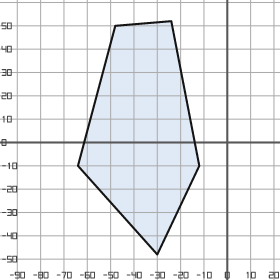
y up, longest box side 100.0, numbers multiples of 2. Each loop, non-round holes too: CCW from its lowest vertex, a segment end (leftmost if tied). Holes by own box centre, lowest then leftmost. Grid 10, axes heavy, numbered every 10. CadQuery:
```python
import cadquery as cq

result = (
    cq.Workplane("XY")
    .moveTo(-30.0, -48.0)
    .lineTo(-12.0, -10.0)
    .lineTo(-24.0, 52.0)
    .lineTo(-48.0, 50.0)
    .lineTo(-64.0, -10.0)
    .close()
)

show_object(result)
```